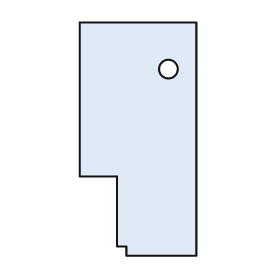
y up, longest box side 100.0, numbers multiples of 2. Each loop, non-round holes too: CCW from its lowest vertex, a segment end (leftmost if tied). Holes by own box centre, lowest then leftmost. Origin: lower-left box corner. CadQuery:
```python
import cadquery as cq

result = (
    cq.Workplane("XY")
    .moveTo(20.0, 0.0)
    .lineTo(50.0, 0.0)
    .lineTo(50.0, 100.0)
    .lineTo(0.0, 100.0)
    .lineTo(0.0, 34.0)
    .lineTo(16.0, 34.0)
    .lineTo(16.0, 4.0)
    .lineTo(20.0, 4.0)
    .close()
    .moveTo(38.0, 80.0)
    .circle(4.0)
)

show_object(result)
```